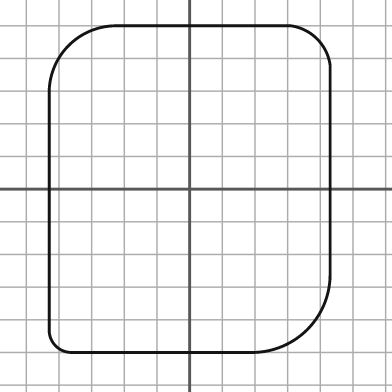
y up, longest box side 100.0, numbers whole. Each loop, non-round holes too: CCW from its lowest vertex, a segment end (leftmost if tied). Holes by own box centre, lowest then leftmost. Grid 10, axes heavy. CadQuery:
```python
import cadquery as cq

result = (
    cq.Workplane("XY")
    .moveTo(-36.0, -50.0)
    .lineTo(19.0, -50.0)
    .threePointArc((36.0, -43.0), (43.0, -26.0))
    .lineTo(43.0, 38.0)
    .threePointArc((39.0, 46.0), (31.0, 50.0))
    .lineTo(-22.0, 50.0)
    .threePointArc((-37.0, 44.0), (-43.0, 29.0))
    .lineTo(-43.0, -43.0)
    .threePointArc((-41.0, -48.0), (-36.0, -50.0))
    .close()
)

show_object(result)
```